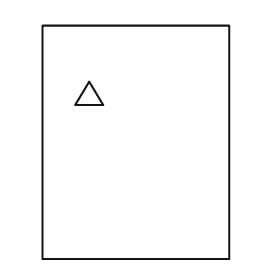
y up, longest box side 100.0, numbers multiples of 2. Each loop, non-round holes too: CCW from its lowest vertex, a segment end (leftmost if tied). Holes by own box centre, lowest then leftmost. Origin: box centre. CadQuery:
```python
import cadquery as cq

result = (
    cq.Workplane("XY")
    .moveTo(-40.0, -50.0)
    .lineTo(40.0, -50.0)
    .lineTo(40.0, 50.0)
    .lineTo(-40.0, 50.0)
    .close()
    .moveTo(-26.0, 16.0)
    .lineTo(-14.0, 16.0)
    .lineTo(-20.0, 26.0)
    .close()
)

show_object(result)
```